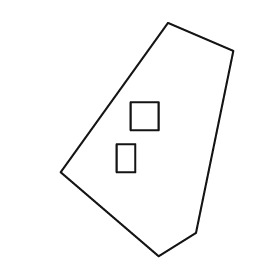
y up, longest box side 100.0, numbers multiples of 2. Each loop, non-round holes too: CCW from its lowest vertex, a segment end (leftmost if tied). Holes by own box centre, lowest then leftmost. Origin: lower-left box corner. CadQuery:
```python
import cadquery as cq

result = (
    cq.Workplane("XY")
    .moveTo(42.0, 0.0)
    .lineTo(58.0, 10.0)
    .lineTo(74.0, 88.0)
    .lineTo(46.0, 100.0)
    .lineTo(0.0, 36.0)
    .close()
    .moveTo(24.0, 36.0)
    .lineTo(32.0, 36.0)
    .lineTo(32.0, 48.0)
    .lineTo(24.0, 48.0)
    .close()
    .moveTo(30.0, 54.0)
    .lineTo(42.0, 54.0)
    .lineTo(42.0, 66.0)
    .lineTo(30.0, 66.0)
    .close()
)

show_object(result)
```